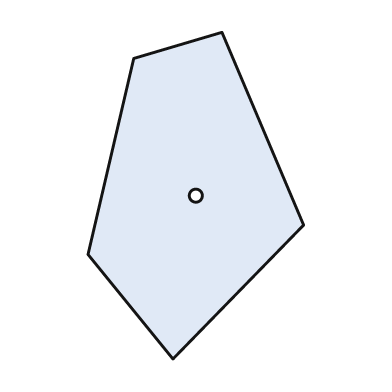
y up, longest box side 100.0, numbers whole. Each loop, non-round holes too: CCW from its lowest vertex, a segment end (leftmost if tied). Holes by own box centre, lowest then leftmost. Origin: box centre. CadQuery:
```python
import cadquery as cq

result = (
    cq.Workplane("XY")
    .moveTo(-7.0, -50.0)
    .lineTo(33.0, -9.0)
    .lineTo(8.0, 50.0)
    .lineTo(-19.0, 42.0)
    .lineTo(-33.0, -18.0)
    .close()
    .moveTo(0.0, 0.0)
    .circle(2.0)
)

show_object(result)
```